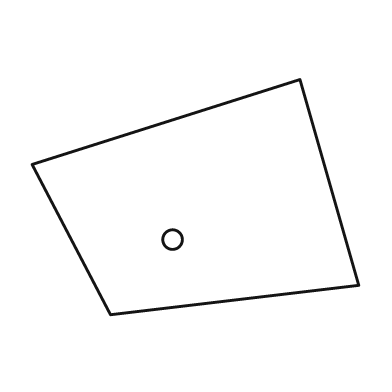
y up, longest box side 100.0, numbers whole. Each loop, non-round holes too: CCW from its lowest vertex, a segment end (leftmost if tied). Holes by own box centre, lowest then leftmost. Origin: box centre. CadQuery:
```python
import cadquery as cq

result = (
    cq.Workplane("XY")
    .moveTo(-26.0, -36.0)
    .lineTo(50.0, -27.0)
    .lineTo(32.0, 36.0)
    .lineTo(-50.0, 10.0)
    .close()
    .moveTo(-7.0, -13.0)
    .circle(3.0)
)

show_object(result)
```